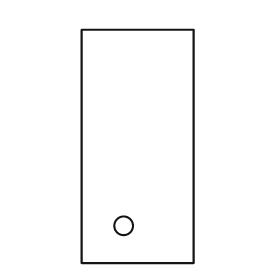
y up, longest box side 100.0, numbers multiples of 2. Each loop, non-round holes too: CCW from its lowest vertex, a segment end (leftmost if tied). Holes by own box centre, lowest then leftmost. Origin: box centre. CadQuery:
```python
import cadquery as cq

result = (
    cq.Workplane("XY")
    .moveTo(-24.0, -50.0)
    .lineTo(24.0, -50.0)
    .lineTo(24.0, 50.0)
    .lineTo(-24.0, 50.0)
    .close()
    .moveTo(-6.0, -34.0)
    .circle(4.0)
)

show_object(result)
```